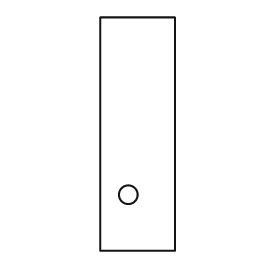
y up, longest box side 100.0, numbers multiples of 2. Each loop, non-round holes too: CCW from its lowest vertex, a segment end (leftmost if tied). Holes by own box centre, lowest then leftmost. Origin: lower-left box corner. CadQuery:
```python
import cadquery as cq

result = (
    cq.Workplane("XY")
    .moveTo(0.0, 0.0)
    .lineTo(32.0, 0.0)
    .lineTo(32.0, 100.0)
    .lineTo(0.0, 100.0)
    .close()
    .moveTo(12.0, 24.0)
    .circle(4.0)
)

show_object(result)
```